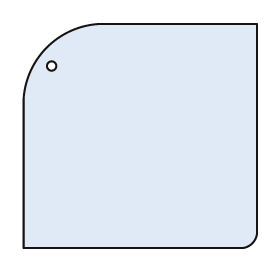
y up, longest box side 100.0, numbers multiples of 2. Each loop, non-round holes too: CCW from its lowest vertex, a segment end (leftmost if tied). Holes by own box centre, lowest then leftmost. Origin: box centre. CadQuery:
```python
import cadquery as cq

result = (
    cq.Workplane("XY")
    .moveTo(-50.0, -48.0)
    .lineTo(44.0, -48.0)
    .threePointArc((48.0, -46.0), (50.0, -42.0))
    .lineTo(50.0, 48.0)
    .lineTo(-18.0, 48.0)
    .threePointArc((-40.0, 38.0), (-50.0, 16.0))
    .close()
    .moveTo(-38.0, 30.0)
    .circle(2.0)
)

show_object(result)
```